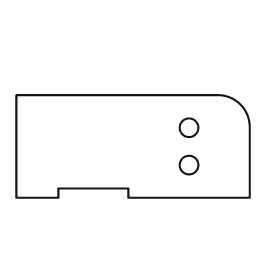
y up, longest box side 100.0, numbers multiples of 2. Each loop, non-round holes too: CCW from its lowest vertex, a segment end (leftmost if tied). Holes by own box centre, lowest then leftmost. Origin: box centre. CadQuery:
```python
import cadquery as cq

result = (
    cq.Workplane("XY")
    .moveTo(-50.0, -22.0)
    .lineTo(-32.0, -22.0)
    .lineTo(-32.0, -18.0)
    .lineTo(-2.0, -18.0)
    .lineTo(-2.0, -22.0)
    .lineTo(50.0, -22.0)
    .lineTo(50.0, 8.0)
    .threePointArc((46.0, 18.0), (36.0, 22.0))
    .lineTo(-50.0, 22.0)
    .close()
    .moveTo(24.0, -8.0)
    .circle(4.0)
    .moveTo(24.0, 8.0)
    .circle(4.0)
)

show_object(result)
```